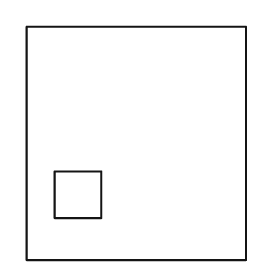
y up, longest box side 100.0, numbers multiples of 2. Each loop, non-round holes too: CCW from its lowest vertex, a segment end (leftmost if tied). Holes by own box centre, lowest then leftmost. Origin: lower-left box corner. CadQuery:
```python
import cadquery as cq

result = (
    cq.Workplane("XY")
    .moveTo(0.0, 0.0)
    .lineTo(94.0, 0.0)
    .lineTo(94.0, 100.0)
    .lineTo(0.0, 100.0)
    .close()
    .moveTo(12.0, 18.0)
    .lineTo(32.0, 18.0)
    .lineTo(32.0, 38.0)
    .lineTo(12.0, 38.0)
    .close()
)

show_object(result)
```